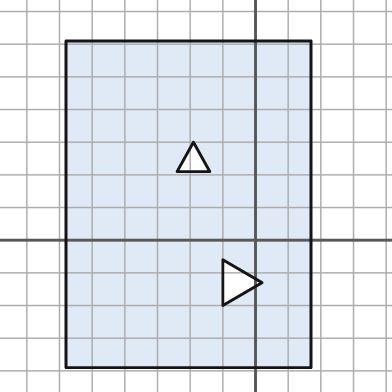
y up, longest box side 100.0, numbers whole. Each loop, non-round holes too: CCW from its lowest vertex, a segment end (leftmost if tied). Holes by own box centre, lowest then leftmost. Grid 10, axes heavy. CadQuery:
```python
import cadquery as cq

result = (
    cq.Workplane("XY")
    .moveTo(-58.0, -39.0)
    .lineTo(17.0, -39.0)
    .lineTo(17.0, 61.0)
    .lineTo(-58.0, 61.0)
    .close()
    .moveTo(-10.0, -20.0)
    .lineTo(2.0, -13.0)
    .lineTo(-10.0, -6.0)
    .close()
    .moveTo(-24.0, 21.0)
    .lineTo(-14.0, 21.0)
    .lineTo(-19.0, 30.0)
    .close()
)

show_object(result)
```